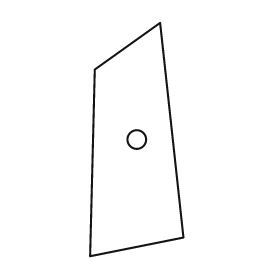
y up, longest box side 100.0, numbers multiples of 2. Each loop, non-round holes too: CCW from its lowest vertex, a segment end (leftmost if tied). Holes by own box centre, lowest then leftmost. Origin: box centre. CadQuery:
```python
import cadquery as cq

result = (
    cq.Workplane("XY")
    .moveTo(-20.0, -50.0)
    .lineTo(20.0, -42.0)
    .lineTo(10.0, 50.0)
    .lineTo(-18.0, 30.0)
    .close()
    .moveTo(0.0, 0.0)
    .circle(4.0)
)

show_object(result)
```